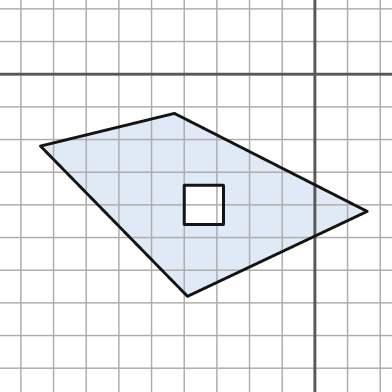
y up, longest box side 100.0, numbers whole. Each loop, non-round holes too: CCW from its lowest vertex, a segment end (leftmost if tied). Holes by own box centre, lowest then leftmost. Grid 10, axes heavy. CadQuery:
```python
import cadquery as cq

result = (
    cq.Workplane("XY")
    .moveTo(-39.0, -68.0)
    .lineTo(16.0, -42.0)
    .lineTo(-43.0, -12.0)
    .lineTo(-84.0, -22.0)
    .close()
    .moveTo(-40.0, -46.0)
    .lineTo(-28.0, -46.0)
    .lineTo(-28.0, -34.0)
    .lineTo(-40.0, -34.0)
    .close()
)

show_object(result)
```